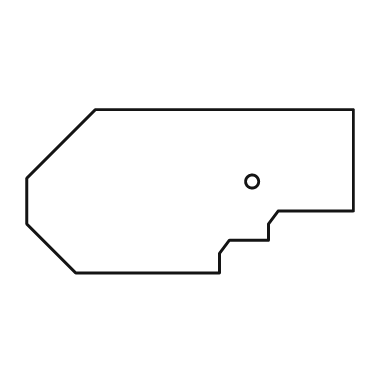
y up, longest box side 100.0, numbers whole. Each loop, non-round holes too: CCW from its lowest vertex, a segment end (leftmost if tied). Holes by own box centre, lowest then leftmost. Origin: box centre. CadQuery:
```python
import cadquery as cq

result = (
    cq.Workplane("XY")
    .moveTo(-35.0, -25.0)
    .lineTo(9.0, -25.0)
    .lineTo(9.0, -19.0)
    .lineTo(12.0, -15.0)
    .lineTo(24.0, -15.0)
    .lineTo(24.0, -10.0)
    .lineTo(27.0, -6.0)
    .lineTo(50.0, -6.0)
    .lineTo(50.0, 25.0)
    .lineTo(-29.0, 25.0)
    .lineTo(-50.0, 4.0)
    .lineTo(-50.0, -10.0)
    .close()
    .moveTo(19.0, 3.0)
    .circle(2.0)
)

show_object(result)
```